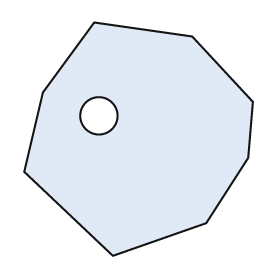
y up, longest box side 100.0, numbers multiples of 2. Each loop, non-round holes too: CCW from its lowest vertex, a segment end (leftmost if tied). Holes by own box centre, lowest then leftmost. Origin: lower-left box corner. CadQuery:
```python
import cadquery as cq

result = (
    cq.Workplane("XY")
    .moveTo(38.0, 0.0)
    .lineTo(78.0, 14.0)
    .lineTo(96.0, 42.0)
    .lineTo(98.0, 66.0)
    .lineTo(72.0, 94.0)
    .lineTo(30.0, 100.0)
    .lineTo(8.0, 70.0)
    .lineTo(0.0, 36.0)
    .close()
    .moveTo(32.0, 60.0)
    .circle(8.0)
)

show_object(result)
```